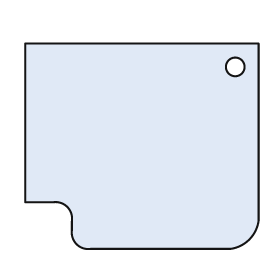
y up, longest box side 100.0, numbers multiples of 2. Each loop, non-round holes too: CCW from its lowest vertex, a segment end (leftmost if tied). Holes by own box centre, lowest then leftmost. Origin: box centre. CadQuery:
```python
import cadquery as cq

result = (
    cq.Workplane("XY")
    .moveTo(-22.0, -44.0)
    .lineTo(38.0, -44.0)
    .threePointArc((46.0, -40.0), (50.0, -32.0))
    .lineTo(50.0, 44.0)
    .lineTo(-50.0, 44.0)
    .lineTo(-50.0, -24.0)
    .lineTo(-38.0, -24.0)
    .threePointArc((-32.0, -26.0), (-30.0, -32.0))
    .lineTo(-30.0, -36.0)
    .threePointArc((-28.0, -42.0), (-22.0, -44.0))
    .close()
    .moveTo(40.0, 34.0)
    .circle(4.0)
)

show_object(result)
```